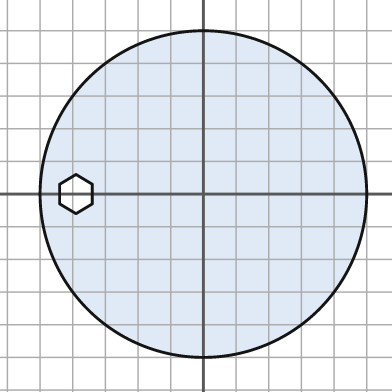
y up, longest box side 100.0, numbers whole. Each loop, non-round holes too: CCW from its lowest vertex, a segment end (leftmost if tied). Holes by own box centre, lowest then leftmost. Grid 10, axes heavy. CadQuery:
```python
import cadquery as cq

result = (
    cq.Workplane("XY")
    .moveTo(0.0, 0.0)
    .circle(50.0)
    .moveTo(-39.0, -6.0)
    .lineTo(-34.0, -3.0)
    .lineTo(-34.0, 3.0)
    .lineTo(-39.0, 6.0)
    .lineTo(-44.0, 3.0)
    .lineTo(-44.0, -3.0)
    .close()
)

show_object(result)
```